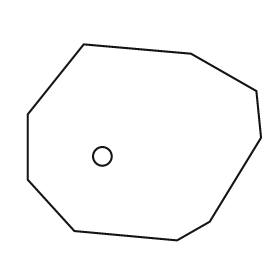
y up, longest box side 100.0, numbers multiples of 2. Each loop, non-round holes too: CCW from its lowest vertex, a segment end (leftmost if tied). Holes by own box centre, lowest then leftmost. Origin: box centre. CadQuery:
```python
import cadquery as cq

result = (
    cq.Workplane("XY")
    .moveTo(14.0, -42.0)
    .lineTo(28.0, -34.0)
    .lineTo(50.0, 2.0)
    .lineTo(48.0, 22.0)
    .lineTo(20.0, 38.0)
    .lineTo(-26.0, 42.0)
    .lineTo(-50.0, 12.0)
    .lineTo(-50.0, -16.0)
    .lineTo(-30.0, -38.0)
    .close()
    .moveTo(-18.0, -6.0)
    .circle(4.0)
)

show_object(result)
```